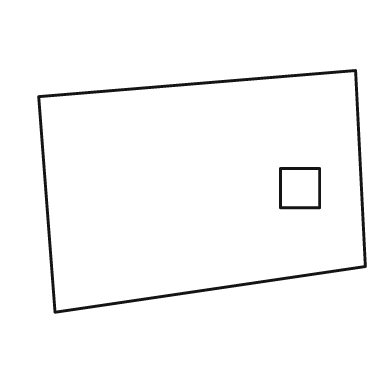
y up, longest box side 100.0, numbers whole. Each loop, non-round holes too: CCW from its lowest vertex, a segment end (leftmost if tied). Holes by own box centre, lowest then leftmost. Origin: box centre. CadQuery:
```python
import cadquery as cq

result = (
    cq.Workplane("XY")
    .moveTo(-45.0, -37.0)
    .lineTo(50.0, -23.0)
    .lineTo(47.0, 37.0)
    .lineTo(-50.0, 29.0)
    .close()
    .moveTo(24.0, -5.0)
    .lineTo(36.0, -5.0)
    .lineTo(36.0, 7.0)
    .lineTo(24.0, 7.0)
    .close()
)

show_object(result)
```